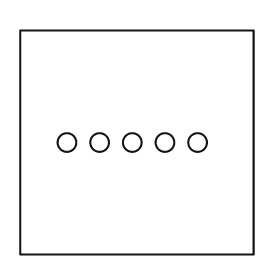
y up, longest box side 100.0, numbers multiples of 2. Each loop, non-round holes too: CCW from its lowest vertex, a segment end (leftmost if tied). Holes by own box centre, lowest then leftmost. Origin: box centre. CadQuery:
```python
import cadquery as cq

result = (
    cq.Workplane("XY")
    .moveTo(-50.0, -48.0)
    .lineTo(50.0, -48.0)
    .lineTo(50.0, 48.0)
    .lineTo(-50.0, 48.0)
    .close()
    .moveTo(-30.0, 0.0)
    .circle(4.0)
    .moveTo(-16.0, 0.0)
    .circle(4.0)
    .moveTo(-2.0, 0.0)
    .circle(4.0)
    .moveTo(12.0, 0.0)
    .circle(4.0)
    .moveTo(26.0, 0.0)
    .circle(4.0)
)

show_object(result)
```